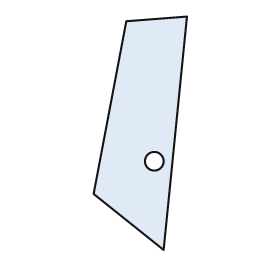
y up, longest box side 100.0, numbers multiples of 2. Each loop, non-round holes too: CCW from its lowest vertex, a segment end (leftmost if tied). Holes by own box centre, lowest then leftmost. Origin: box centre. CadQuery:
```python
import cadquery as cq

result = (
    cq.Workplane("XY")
    .moveTo(10.0, -50.0)
    .lineTo(20.0, 50.0)
    .lineTo(-6.0, 48.0)
    .lineTo(-20.0, -26.0)
    .close()
    .moveTo(6.0, -12.0)
    .circle(4.0)
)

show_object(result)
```